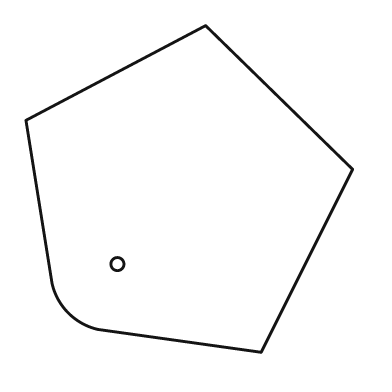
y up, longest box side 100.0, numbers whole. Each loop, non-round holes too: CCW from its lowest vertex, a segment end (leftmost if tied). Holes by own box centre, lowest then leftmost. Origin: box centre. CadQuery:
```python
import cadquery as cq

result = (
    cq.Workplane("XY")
    .moveTo(22.0, -50.0)
    .lineTo(50.0, 6.0)
    .lineTo(5.0, 50.0)
    .lineTo(-50.0, 21.0)
    .lineTo(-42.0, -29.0)
    .threePointArc((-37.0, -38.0), (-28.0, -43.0))
    .close()
    .moveTo(-22.0, -23.0)
    .circle(2.0)
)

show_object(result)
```